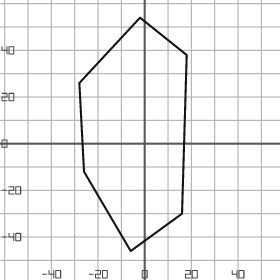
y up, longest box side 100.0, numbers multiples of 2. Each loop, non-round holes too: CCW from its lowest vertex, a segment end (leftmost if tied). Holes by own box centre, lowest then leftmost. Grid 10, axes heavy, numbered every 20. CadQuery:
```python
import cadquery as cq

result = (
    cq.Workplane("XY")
    .moveTo(-6.0, -46.0)
    .lineTo(16.0, -30.0)
    .lineTo(18.0, 38.0)
    .lineTo(-2.0, 54.0)
    .lineTo(-28.0, 26.0)
    .lineTo(-26.0, -12.0)
    .close()
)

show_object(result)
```